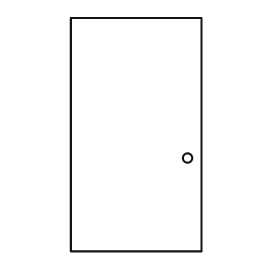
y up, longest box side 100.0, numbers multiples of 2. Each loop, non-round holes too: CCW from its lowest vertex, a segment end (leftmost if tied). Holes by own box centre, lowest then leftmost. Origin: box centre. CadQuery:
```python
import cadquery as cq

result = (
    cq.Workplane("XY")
    .moveTo(-28.0, -50.0)
    .lineTo(28.0, -50.0)
    .lineTo(28.0, 50.0)
    .lineTo(-28.0, 50.0)
    .close()
    .moveTo(22.0, -10.0)
    .circle(2.0)
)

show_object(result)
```